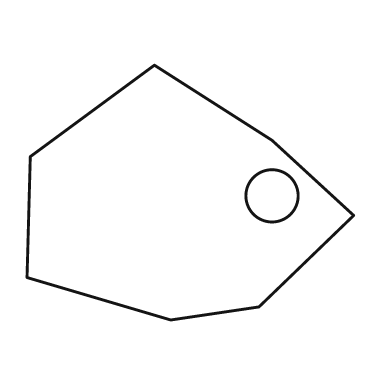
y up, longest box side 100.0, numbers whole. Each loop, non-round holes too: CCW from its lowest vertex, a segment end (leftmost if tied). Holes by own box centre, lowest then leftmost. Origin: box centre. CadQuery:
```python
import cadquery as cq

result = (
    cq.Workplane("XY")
    .moveTo(-6.0, -39.0)
    .lineTo(21.0, -35.0)
    .lineTo(50.0, -7.0)
    .lineTo(25.0, 16.0)
    .lineTo(-11.0, 39.0)
    .lineTo(-49.0, 11.0)
    .lineTo(-50.0, -26.0)
    .close()
    .moveTo(25.0, -1.0)
    .circle(8.0)
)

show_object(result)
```